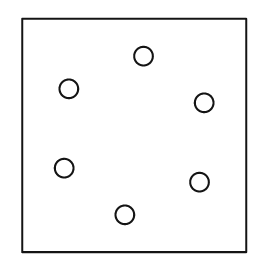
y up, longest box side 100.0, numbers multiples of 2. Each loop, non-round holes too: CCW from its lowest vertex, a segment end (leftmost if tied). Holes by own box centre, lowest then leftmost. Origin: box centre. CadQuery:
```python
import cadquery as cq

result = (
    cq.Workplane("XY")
    .moveTo(-48.0, -50.0)
    .lineTo(48.0, -50.0)
    .lineTo(48.0, 50.0)
    .lineTo(-48.0, 50.0)
    .close()
    .moveTo(-4.0, -34.0)
    .circle(4.0)
    .moveTo(28.0, -20.0)
    .circle(4.0)
    .moveTo(-30.0, -14.0)
    .circle(4.0)
    .moveTo(30.0, 14.0)
    .circle(4.0)
    .moveTo(-28.0, 20.0)
    .circle(4.0)
    .moveTo(4.0, 34.0)
    .circle(4.0)
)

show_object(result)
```